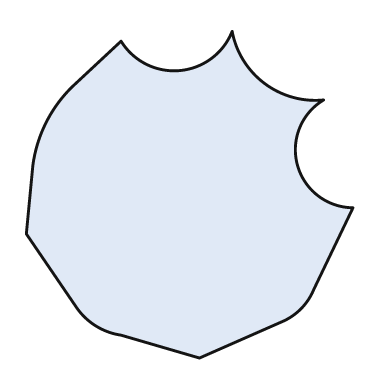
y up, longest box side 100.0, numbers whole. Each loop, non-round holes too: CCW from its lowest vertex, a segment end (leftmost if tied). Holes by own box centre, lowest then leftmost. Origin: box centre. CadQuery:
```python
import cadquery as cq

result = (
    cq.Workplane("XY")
    .moveTo(3.0, -50.0)
    .lineTo(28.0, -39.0)
    .threePointArc((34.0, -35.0), (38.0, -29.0))
    .lineTo(50.0, -4.0)
    .threePointArc((33.0, 9.0), (41.0, 29.0))
    .threePointArc((23.0, 34.0), (13.0, 50.0))
    .threePointArc((-3.0, 38.0), (-21.0, 47.0))
    .lineTo(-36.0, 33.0)
    .threePointArc((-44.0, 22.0), (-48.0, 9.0))
    .lineTo(-50.0, -12.0)
    .lineTo(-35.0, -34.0)
    .threePointArc((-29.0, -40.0), (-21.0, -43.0))
    .close()
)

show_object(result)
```